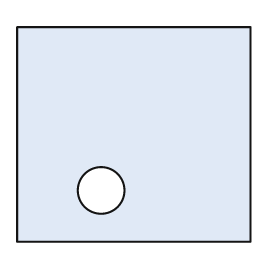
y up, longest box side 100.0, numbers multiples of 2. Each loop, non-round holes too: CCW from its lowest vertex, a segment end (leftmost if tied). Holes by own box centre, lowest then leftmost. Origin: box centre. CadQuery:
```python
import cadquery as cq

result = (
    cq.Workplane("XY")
    .moveTo(-50.0, -46.0)
    .lineTo(50.0, -46.0)
    .lineTo(50.0, 46.0)
    .lineTo(-50.0, 46.0)
    .close()
    .moveTo(-14.0, -24.0)
    .circle(10.0)
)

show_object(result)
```